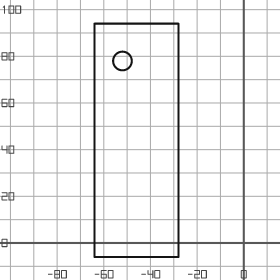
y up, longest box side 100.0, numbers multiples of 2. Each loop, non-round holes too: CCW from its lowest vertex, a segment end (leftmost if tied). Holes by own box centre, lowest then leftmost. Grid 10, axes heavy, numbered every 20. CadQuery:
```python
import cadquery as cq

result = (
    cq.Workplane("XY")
    .moveTo(-64.0, -6.0)
    .lineTo(-28.0, -6.0)
    .lineTo(-28.0, 94.0)
    .lineTo(-64.0, 94.0)
    .close()
    .moveTo(-52.0, 78.0)
    .circle(4.0)
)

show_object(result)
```